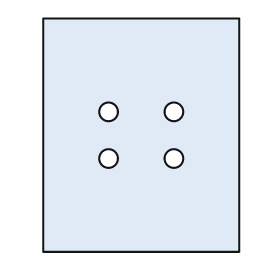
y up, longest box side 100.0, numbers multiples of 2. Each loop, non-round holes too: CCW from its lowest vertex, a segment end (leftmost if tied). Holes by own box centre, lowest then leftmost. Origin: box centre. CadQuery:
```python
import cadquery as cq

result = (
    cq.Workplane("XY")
    .moveTo(-42.0, -50.0)
    .lineTo(42.0, -50.0)
    .lineTo(42.0, 50.0)
    .lineTo(-42.0, 50.0)
    .close()
    .moveTo(-14.0, -10.0)
    .circle(4.0)
    .moveTo(14.0, -10.0)
    .circle(4.0)
    .moveTo(-14.0, 10.0)
    .circle(4.0)
    .moveTo(14.0, 10.0)
    .circle(4.0)
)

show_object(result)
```